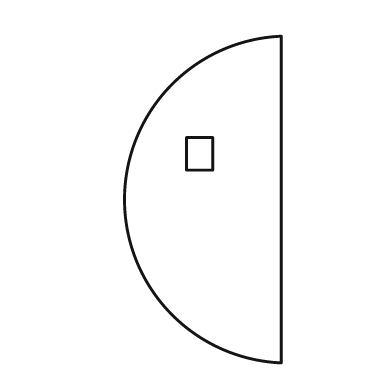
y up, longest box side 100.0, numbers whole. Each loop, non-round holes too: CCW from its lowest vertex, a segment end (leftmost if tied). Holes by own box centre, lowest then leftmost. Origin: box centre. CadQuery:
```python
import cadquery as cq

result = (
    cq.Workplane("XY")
    .moveTo(24.0, -50.0)
    .lineTo(24.0, 50.0)
    .threePointArc((-24.0, 0.0), (24.0, -50.0))
    .close()
    .moveTo(-5.0, 9.0)
    .lineTo(3.0, 9.0)
    .lineTo(3.0, 19.0)
    .lineTo(-5.0, 19.0)
    .close()
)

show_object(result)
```